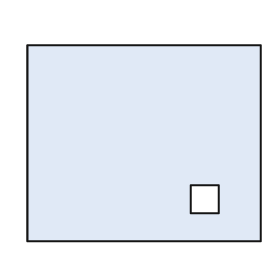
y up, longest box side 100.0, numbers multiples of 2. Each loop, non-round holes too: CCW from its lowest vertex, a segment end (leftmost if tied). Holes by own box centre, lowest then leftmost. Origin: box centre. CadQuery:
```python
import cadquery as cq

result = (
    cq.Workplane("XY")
    .moveTo(-50.0, -42.0)
    .lineTo(50.0, -42.0)
    .lineTo(50.0, 42.0)
    .lineTo(-50.0, 42.0)
    .close()
    .moveTo(20.0, -30.0)
    .lineTo(32.0, -30.0)
    .lineTo(32.0, -18.0)
    .lineTo(20.0, -18.0)
    .close()
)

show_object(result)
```